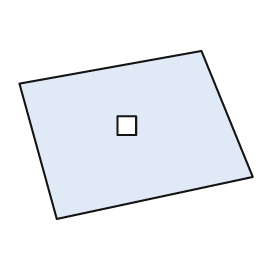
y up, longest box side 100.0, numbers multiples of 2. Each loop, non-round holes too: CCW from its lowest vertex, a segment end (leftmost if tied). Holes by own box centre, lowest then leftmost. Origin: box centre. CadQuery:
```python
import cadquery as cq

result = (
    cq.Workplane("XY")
    .moveTo(-34.0, -36.0)
    .lineTo(50.0, -18.0)
    .lineTo(28.0, 36.0)
    .lineTo(-50.0, 22.0)
    .close()
    .moveTo(-8.0, 0.0)
    .lineTo(0.0, 0.0)
    .lineTo(0.0, 8.0)
    .lineTo(-8.0, 8.0)
    .close()
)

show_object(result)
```